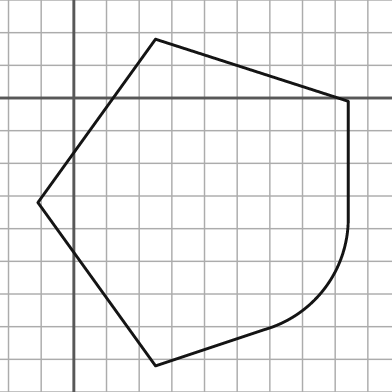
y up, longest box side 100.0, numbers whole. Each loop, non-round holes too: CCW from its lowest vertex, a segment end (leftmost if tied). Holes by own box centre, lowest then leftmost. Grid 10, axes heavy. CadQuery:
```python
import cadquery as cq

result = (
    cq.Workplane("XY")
    .moveTo(25.0, -82.0)
    .lineTo(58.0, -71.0)
    .threePointArc((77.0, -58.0), (84.0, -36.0))
    .lineTo(84.0, -1.0)
    .lineTo(25.0, 18.0)
    .lineTo(-11.0, -32.0)
    .close()
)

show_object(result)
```